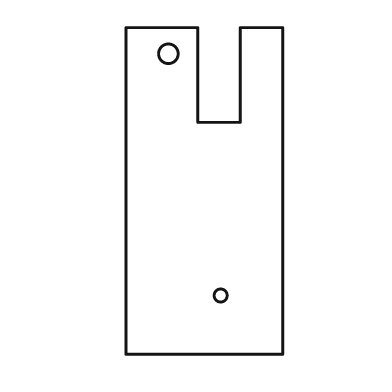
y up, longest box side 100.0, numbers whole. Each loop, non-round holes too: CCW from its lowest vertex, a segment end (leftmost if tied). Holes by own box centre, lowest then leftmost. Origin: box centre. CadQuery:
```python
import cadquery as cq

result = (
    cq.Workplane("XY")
    .moveTo(-24.0, -50.0)
    .lineTo(24.0, -50.0)
    .lineTo(24.0, 50.0)
    .lineTo(11.0, 50.0)
    .lineTo(11.0, 21.0)
    .lineTo(-2.0, 21.0)
    .lineTo(-2.0, 50.0)
    .lineTo(-24.0, 50.0)
    .close()
    .moveTo(5.0, -32.0)
    .circle(2.0)
    .moveTo(-11.0, 42.0)
    .circle(3.0)
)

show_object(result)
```